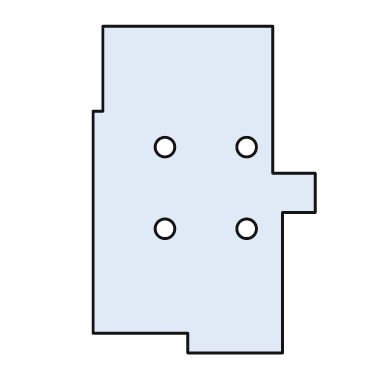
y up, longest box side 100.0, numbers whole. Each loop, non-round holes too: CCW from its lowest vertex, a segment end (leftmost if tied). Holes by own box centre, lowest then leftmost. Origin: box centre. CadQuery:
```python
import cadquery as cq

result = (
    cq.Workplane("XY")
    .moveTo(-5.0, -50.0)
    .lineTo(24.0, -50.0)
    .lineTo(24.0, -7.0)
    .lineTo(34.0, -7.0)
    .lineTo(34.0, 5.0)
    .lineTo(21.0, 5.0)
    .lineTo(21.0, 50.0)
    .lineTo(-31.0, 50.0)
    .lineTo(-31.0, 24.0)
    .lineTo(-34.0, 24.0)
    .lineTo(-34.0, -44.0)
    .lineTo(-5.0, -44.0)
    .close()
    .moveTo(-12.0, -12.0)
    .circle(3.0)
    .moveTo(13.0, -12.0)
    .circle(3.0)
    .moveTo(-12.0, 13.0)
    .circle(3.0)
    .moveTo(13.0, 13.0)
    .circle(3.0)
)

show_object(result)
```